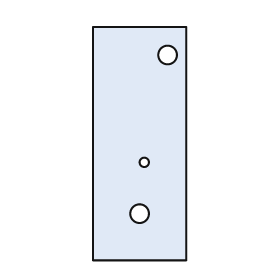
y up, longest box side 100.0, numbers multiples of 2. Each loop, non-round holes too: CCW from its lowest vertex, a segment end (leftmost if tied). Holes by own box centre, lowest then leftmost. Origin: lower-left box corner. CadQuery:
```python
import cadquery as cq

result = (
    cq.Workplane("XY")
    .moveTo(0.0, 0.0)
    .lineTo(40.0, 0.0)
    .lineTo(40.0, 100.0)
    .lineTo(0.0, 100.0)
    .close()
    .moveTo(20.0, 20.0)
    .circle(4.0)
    .moveTo(22.0, 42.0)
    .circle(2.0)
    .moveTo(32.0, 88.0)
    .circle(4.0)
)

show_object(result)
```